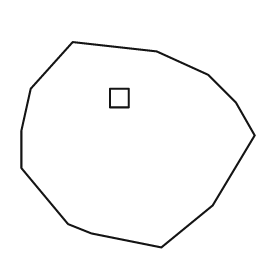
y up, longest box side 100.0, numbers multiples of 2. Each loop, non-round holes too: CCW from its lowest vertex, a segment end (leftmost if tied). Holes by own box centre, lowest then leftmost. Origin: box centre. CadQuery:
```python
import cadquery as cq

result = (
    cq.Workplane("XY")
    .moveTo(10.0, -44.0)
    .lineTo(32.0, -26.0)
    .lineTo(50.0, 4.0)
    .lineTo(42.0, 18.0)
    .lineTo(30.0, 30.0)
    .lineTo(8.0, 40.0)
    .lineTo(-28.0, 44.0)
    .lineTo(-46.0, 24.0)
    .lineTo(-50.0, 6.0)
    .lineTo(-50.0, -10.0)
    .lineTo(-30.0, -34.0)
    .lineTo(-20.0, -38.0)
    .close()
    .moveTo(-12.0, 16.0)
    .lineTo(-4.0, 16.0)
    .lineTo(-4.0, 24.0)
    .lineTo(-12.0, 24.0)
    .close()
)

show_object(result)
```